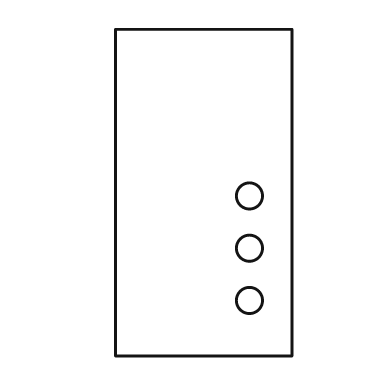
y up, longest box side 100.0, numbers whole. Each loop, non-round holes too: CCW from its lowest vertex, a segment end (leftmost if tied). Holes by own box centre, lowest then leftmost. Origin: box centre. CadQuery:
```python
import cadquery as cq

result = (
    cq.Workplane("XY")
    .moveTo(-27.0, -50.0)
    .lineTo(27.0, -50.0)
    .lineTo(27.0, 50.0)
    .lineTo(-27.0, 50.0)
    .close()
    .moveTo(14.0, -33.0)
    .circle(4.0)
    .moveTo(14.0, -17.0)
    .circle(4.0)
    .moveTo(14.0, -1.0)
    .circle(4.0)
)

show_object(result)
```